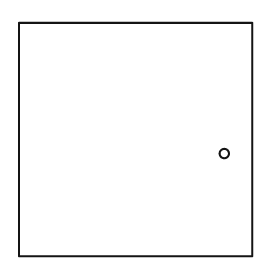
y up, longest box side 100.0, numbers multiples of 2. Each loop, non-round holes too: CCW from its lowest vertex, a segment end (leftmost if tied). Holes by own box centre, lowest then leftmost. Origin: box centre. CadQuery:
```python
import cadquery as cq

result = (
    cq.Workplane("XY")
    .moveTo(-50.0, -50.0)
    .lineTo(50.0, -50.0)
    .lineTo(50.0, 50.0)
    .lineTo(-50.0, 50.0)
    .close()
    .moveTo(38.0, -6.0)
    .circle(2.0)
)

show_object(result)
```